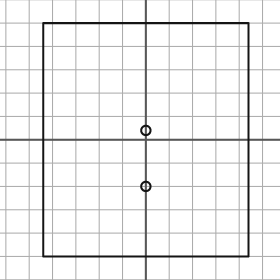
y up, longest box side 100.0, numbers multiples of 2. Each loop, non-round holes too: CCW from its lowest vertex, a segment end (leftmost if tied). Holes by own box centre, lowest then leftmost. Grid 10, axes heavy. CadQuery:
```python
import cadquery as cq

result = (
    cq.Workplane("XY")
    .moveTo(-44.0, -50.0)
    .lineTo(44.0, -50.0)
    .lineTo(44.0, 50.0)
    .lineTo(-44.0, 50.0)
    .close()
    .moveTo(0.0, -20.0)
    .circle(2.0)
    .moveTo(0.0, 4.0)
    .circle(2.0)
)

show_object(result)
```